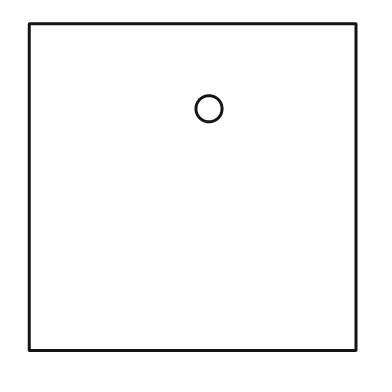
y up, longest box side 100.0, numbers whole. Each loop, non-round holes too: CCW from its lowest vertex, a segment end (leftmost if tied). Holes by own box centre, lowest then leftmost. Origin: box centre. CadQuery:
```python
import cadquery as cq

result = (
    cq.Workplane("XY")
    .moveTo(-50.0, -50.0)
    .lineTo(50.0, -50.0)
    .lineTo(50.0, 50.0)
    .lineTo(-50.0, 50.0)
    .close()
    .moveTo(5.0, 24.0)
    .circle(4.0)
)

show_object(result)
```